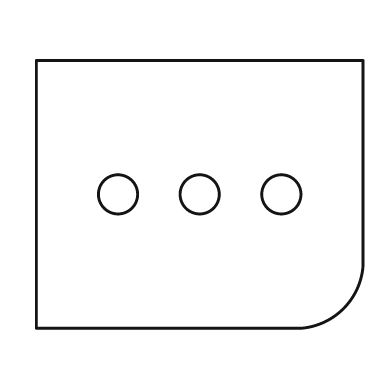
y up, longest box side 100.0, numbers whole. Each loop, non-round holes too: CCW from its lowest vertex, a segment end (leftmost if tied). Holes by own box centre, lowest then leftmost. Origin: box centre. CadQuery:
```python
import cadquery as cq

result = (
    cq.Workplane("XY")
    .moveTo(-50.0, -41.0)
    .lineTo(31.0, -41.0)
    .threePointArc((44.0, -35.0), (50.0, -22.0))
    .lineTo(50.0, 41.0)
    .lineTo(-50.0, 41.0)
    .close()
    .moveTo(-25.0, 0.0)
    .circle(6.0)
    .moveTo(0.0, 0.0)
    .circle(6.0)
    .moveTo(25.0, 0.0)
    .circle(6.0)
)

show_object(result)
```